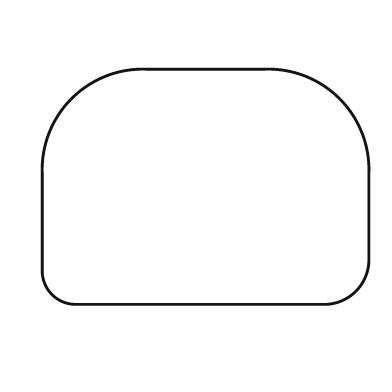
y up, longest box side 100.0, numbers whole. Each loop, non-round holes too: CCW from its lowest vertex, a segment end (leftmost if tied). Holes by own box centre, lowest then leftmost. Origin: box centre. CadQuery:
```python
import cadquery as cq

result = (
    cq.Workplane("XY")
    .moveTo(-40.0, -36.0)
    .lineTo(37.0, -36.0)
    .threePointArc((46.0, -32.0), (50.0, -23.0))
    .lineTo(50.0, 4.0)
    .threePointArc((41.0, 27.0), (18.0, 36.0))
    .lineTo(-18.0, 36.0)
    .threePointArc((-41.0, 27.0), (-50.0, 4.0))
    .lineTo(-50.0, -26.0)
    .threePointArc((-47.0, -33.0), (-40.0, -36.0))
    .close()
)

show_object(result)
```